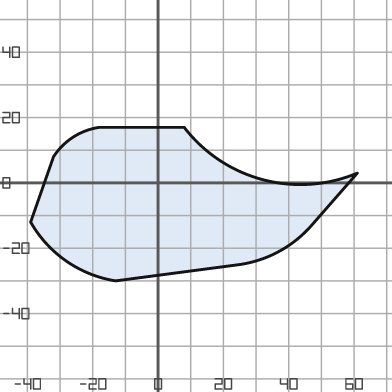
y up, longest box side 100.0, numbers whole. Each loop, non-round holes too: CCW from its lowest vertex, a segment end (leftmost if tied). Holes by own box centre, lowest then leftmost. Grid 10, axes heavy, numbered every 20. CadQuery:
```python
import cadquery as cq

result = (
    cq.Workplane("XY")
    .moveTo(-13.0, -30.0)
    .lineTo(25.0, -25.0)
    .threePointArc((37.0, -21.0), (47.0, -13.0))
    .lineTo(61.0, 3.0)
    .threePointArc((32.0, 1.0), (8.0, 17.0))
    .lineTo(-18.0, 17.0)
    .threePointArc((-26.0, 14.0), (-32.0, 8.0))
    .lineTo(-39.0, -12.0)
    .threePointArc((-28.0, -24.0), (-13.0, -30.0))
    .close()
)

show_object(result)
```